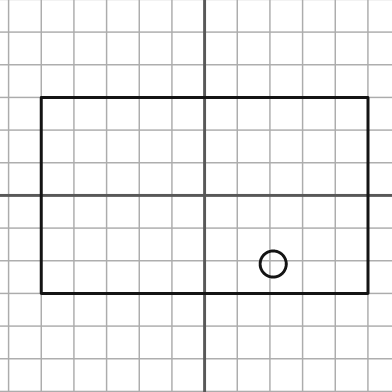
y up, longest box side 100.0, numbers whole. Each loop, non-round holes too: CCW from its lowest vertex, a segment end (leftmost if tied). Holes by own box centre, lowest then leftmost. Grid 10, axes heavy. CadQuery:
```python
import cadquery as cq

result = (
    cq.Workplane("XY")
    .moveTo(-50.0, -30.0)
    .lineTo(50.0, -30.0)
    .lineTo(50.0, 30.0)
    .lineTo(-50.0, 30.0)
    .close()
    .moveTo(21.0, -21.0)
    .circle(4.0)
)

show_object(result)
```